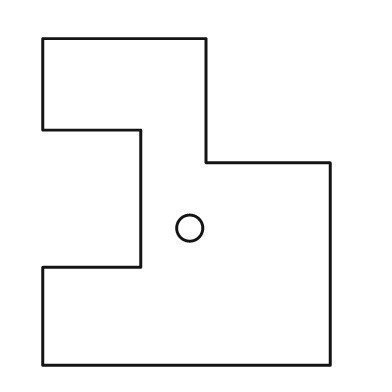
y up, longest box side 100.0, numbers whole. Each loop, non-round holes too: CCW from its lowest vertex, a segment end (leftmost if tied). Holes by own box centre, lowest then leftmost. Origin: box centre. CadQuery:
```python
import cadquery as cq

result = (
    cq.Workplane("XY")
    .moveTo(-44.0, -50.0)
    .lineTo(44.0, -50.0)
    .lineTo(44.0, 12.0)
    .lineTo(6.0, 12.0)
    .lineTo(6.0, 50.0)
    .lineTo(-44.0, 50.0)
    .lineTo(-44.0, 22.0)
    .lineTo(-14.0, 22.0)
    .lineTo(-14.0, -20.0)
    .lineTo(-44.0, -20.0)
    .close()
    .moveTo(1.0, -8.0)
    .circle(4.0)
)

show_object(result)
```